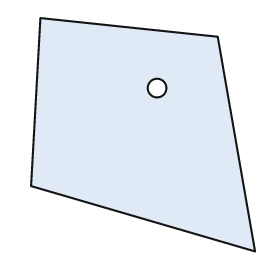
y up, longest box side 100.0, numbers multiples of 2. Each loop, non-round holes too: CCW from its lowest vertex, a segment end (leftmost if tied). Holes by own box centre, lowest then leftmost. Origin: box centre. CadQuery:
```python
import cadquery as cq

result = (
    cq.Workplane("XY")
    .moveTo(48.0, -50.0)
    .lineTo(32.0, 42.0)
    .lineTo(-44.0, 50.0)
    .lineTo(-48.0, -22.0)
    .close()
    .moveTo(6.0, 20.0)
    .circle(4.0)
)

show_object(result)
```